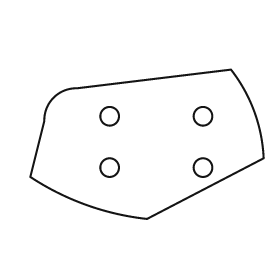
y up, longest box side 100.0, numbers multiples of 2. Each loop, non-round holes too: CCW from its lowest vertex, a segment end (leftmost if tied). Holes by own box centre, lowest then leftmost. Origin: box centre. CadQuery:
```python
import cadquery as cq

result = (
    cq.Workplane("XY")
    .moveTo(0.0, -32.0)
    .lineTo(50.0, -6.0)
    .threePointArc((46.0, 14.0), (36.0, 32.0))
    .lineTo(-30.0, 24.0)
    .threePointArc((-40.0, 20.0), (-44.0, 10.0))
    .lineTo(-50.0, -14.0)
    .threePointArc((-26.0, -26.0), (0.0, -32.0))
    .close()
    .moveTo(-16.0, -10.0)
    .circle(4.0)
    .moveTo(24.0, -10.0)
    .circle(4.0)
    .moveTo(-16.0, 12.0)
    .circle(4.0)
    .moveTo(24.0, 12.0)
    .circle(4.0)
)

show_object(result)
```